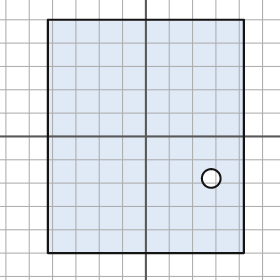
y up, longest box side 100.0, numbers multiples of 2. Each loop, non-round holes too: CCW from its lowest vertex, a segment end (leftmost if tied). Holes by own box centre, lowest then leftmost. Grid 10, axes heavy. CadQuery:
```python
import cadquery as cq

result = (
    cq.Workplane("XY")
    .moveTo(-42.0, -50.0)
    .lineTo(42.0, -50.0)
    .lineTo(42.0, 50.0)
    .lineTo(-42.0, 50.0)
    .close()
    .moveTo(28.0, -18.0)
    .circle(4.0)
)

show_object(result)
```